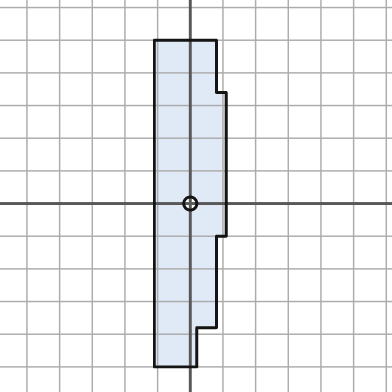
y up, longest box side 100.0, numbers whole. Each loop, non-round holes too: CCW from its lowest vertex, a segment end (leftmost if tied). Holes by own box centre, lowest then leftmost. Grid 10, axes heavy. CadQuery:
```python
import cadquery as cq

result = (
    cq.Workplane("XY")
    .moveTo(-11.0, -50.0)
    .lineTo(2.0, -50.0)
    .lineTo(2.0, -38.0)
    .lineTo(8.0, -38.0)
    .lineTo(8.0, -10.0)
    .lineTo(11.0, -10.0)
    .lineTo(11.0, 34.0)
    .lineTo(8.0, 34.0)
    .lineTo(8.0, 50.0)
    .lineTo(-11.0, 50.0)
    .close()
    .moveTo(0.0, 0.0)
    .circle(2.0)
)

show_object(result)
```